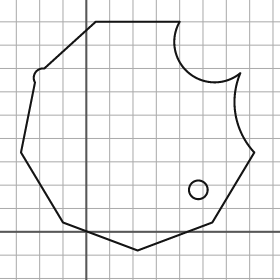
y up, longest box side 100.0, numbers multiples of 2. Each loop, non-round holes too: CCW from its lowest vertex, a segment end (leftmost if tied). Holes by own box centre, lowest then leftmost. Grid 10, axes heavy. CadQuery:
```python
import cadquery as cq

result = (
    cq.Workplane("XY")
    .moveTo(22.0, -8.0)
    .lineTo(54.0, 4.0)
    .lineTo(72.0, 34.0)
    .threePointArc((64.0, 50.0), (66.0, 68.0))
    .threePointArc((44.0, 68.0), (40.0, 90.0))
    .lineTo(4.0, 90.0)
    .lineTo(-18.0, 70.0)
    .threePointArc((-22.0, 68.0), (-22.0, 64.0))
    .lineTo(-28.0, 34.0)
    .lineTo(-10.0, 4.0)
    .close()
    .moveTo(48.0, 18.0)
    .circle(4.0)
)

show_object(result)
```